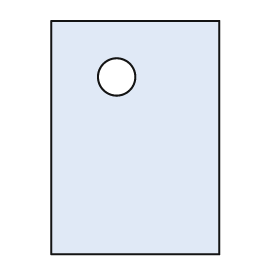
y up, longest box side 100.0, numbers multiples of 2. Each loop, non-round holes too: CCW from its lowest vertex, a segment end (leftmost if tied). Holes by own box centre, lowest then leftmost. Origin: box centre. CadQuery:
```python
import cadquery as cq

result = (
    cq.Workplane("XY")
    .moveTo(-36.0, -50.0)
    .lineTo(36.0, -50.0)
    .lineTo(36.0, 50.0)
    .lineTo(-36.0, 50.0)
    .close()
    .moveTo(-8.0, 26.0)
    .circle(8.0)
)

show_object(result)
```